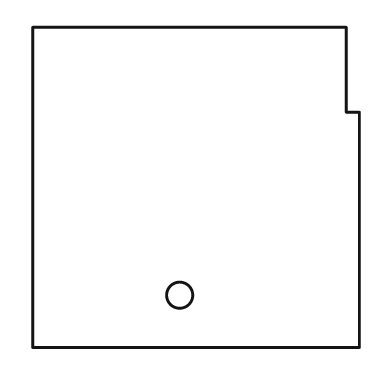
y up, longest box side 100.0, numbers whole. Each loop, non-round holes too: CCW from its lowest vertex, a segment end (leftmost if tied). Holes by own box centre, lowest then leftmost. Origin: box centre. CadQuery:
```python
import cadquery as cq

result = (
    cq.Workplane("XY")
    .moveTo(-50.0, -49.0)
    .lineTo(50.0, -49.0)
    .lineTo(50.0, 23.0)
    .lineTo(46.0, 23.0)
    .lineTo(46.0, 49.0)
    .lineTo(-50.0, 49.0)
    .close()
    .moveTo(-5.0, -33.0)
    .circle(4.0)
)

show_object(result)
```